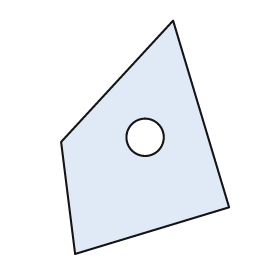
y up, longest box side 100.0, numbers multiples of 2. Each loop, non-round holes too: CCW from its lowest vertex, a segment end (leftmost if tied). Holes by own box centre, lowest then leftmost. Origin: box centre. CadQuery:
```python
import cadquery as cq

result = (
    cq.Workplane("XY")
    .moveTo(-30.0, -50.0)
    .lineTo(36.0, -30.0)
    .lineTo(12.0, 50.0)
    .lineTo(-36.0, -2.0)
    .close()
    .moveTo(0.0, 0.0)
    .circle(8.0)
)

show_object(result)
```